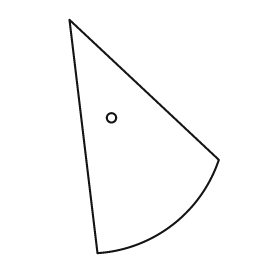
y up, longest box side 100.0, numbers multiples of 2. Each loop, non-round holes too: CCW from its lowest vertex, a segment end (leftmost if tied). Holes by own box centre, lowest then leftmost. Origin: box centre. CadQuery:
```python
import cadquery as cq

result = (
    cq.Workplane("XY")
    .moveTo(-20.0, -50.0)
    .threePointArc((12.0, -38.0), (32.0, -10.0))
    .lineTo(-32.0, 50.0)
    .close()
    .moveTo(-14.0, 8.0)
    .circle(2.0)
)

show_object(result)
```